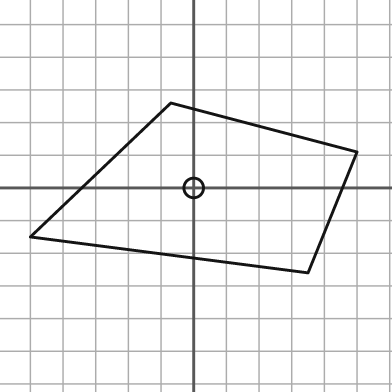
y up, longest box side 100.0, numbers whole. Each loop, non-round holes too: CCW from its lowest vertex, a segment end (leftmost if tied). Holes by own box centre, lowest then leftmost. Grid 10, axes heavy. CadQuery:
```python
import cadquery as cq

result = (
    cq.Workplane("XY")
    .moveTo(35.0, -26.0)
    .lineTo(50.0, 11.0)
    .lineTo(-7.0, 26.0)
    .lineTo(-50.0, -15.0)
    .close()
    .moveTo(0.0, 0.0)
    .circle(3.0)
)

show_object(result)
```